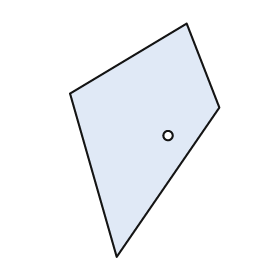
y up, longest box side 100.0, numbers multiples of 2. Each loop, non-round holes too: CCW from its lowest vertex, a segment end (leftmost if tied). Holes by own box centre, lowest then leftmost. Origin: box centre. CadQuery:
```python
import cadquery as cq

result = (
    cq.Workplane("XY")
    .moveTo(-12.0, -50.0)
    .lineTo(32.0, 14.0)
    .lineTo(18.0, 50.0)
    .lineTo(-32.0, 20.0)
    .close()
    .moveTo(10.0, 2.0)
    .circle(2.0)
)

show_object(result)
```